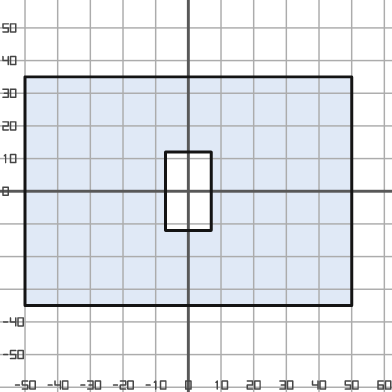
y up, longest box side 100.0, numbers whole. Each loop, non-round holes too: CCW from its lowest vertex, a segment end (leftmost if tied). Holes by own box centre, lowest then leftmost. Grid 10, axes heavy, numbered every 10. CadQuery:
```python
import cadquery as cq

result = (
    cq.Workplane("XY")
    .moveTo(-50.0, -35.0)
    .lineTo(50.0, -35.0)
    .lineTo(50.0, 35.0)
    .lineTo(-50.0, 35.0)
    .close()
    .moveTo(-7.0, -12.0)
    .lineTo(7.0, -12.0)
    .lineTo(7.0, 12.0)
    .lineTo(-7.0, 12.0)
    .close()
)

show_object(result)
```